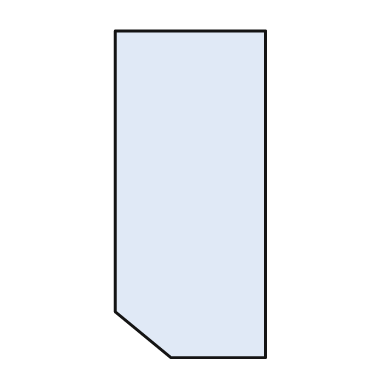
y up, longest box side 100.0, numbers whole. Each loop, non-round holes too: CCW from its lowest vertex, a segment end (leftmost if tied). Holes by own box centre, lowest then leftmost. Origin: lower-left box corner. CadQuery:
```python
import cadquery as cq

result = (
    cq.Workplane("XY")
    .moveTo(17.0, 0.0)
    .lineTo(46.0, 0.0)
    .lineTo(46.0, 100.0)
    .lineTo(0.0, 100.0)
    .lineTo(0.0, 14.0)
    .close()
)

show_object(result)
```